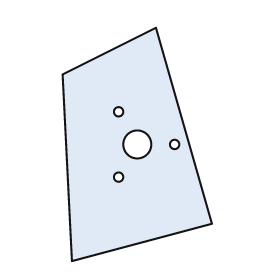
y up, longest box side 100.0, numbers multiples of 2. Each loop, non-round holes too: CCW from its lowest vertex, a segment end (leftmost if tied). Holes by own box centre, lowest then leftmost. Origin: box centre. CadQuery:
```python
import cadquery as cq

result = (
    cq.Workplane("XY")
    .moveTo(-28.0, -50.0)
    .lineTo(32.0, -34.0)
    .lineTo(8.0, 50.0)
    .lineTo(-32.0, 30.0)
    .close()
    .moveTo(-8.0, -14.0)
    .circle(2.0)
    .moveTo(0.0, 0.0)
    .circle(6.0)
    .moveTo(16.0, 0.0)
    .circle(2.0)
    .moveTo(-8.0, 14.0)
    .circle(2.0)
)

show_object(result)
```